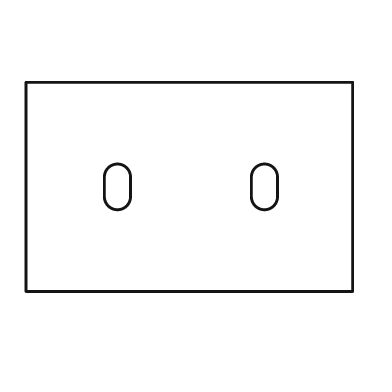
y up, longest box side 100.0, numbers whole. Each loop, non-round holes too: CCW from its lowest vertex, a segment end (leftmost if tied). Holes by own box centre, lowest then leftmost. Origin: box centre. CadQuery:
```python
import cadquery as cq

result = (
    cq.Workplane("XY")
    .moveTo(-50.0, -32.0)
    .lineTo(50.0, -32.0)
    .lineTo(50.0, 32.0)
    .lineTo(-50.0, 32.0)
    .close()
    .moveTo(-26.0, -3.0)
    .threePointArc((-22.0, -7.0), (-18.0, -3.0))
    .lineTo(-18.0, 3.0)
    .threePointArc((-22.0, 7.0), (-26.0, 3.0))
    .close()
    .moveTo(19.0, -3.0)
    .threePointArc((23.0, -7.0), (27.0, -3.0))
    .lineTo(27.0, 3.0)
    .threePointArc((23.0, 7.0), (19.0, 3.0))
    .close()
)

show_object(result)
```